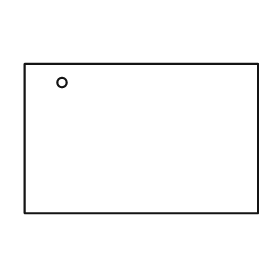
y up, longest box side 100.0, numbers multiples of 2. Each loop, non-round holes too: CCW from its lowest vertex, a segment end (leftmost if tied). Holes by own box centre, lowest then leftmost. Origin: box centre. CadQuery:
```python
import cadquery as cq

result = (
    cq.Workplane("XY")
    .moveTo(-50.0, -32.0)
    .lineTo(50.0, -32.0)
    .lineTo(50.0, 32.0)
    .lineTo(-50.0, 32.0)
    .close()
    .moveTo(-34.0, 24.0)
    .circle(2.0)
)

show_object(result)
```